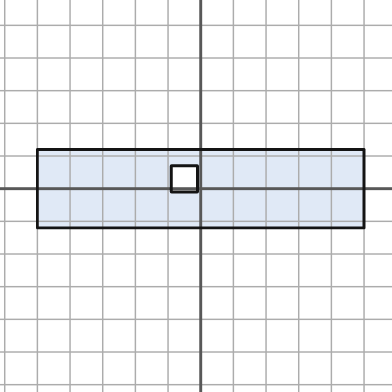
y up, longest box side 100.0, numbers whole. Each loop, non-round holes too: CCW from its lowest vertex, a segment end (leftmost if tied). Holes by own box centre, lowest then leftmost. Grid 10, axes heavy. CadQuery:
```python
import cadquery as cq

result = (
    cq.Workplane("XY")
    .moveTo(-50.0, -12.0)
    .lineTo(50.0, -12.0)
    .lineTo(50.0, 12.0)
    .lineTo(-50.0, 12.0)
    .close()
    .moveTo(-9.0, -1.0)
    .lineTo(-1.0, -1.0)
    .lineTo(-1.0, 7.0)
    .lineTo(-9.0, 7.0)
    .close()
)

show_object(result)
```